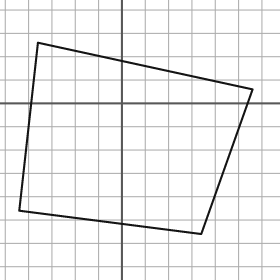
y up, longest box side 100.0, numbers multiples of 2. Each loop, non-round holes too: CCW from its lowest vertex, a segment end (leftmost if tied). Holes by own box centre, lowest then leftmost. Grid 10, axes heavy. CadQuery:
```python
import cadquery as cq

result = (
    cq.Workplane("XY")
    .moveTo(34.0, -56.0)
    .lineTo(56.0, 6.0)
    .lineTo(-36.0, 26.0)
    .lineTo(-44.0, -46.0)
    .close()
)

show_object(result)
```